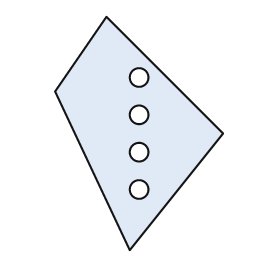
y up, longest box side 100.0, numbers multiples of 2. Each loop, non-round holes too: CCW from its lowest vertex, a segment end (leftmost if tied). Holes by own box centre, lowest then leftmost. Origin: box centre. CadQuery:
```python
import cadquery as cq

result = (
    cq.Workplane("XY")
    .moveTo(-4.0, -50.0)
    .lineTo(36.0, 0.0)
    .lineTo(-14.0, 50.0)
    .lineTo(-36.0, 18.0)
    .close()
    .moveTo(0.0, -24.0)
    .circle(4.0)
    .moveTo(0.0, -8.0)
    .circle(4.0)
    .moveTo(0.0, 8.0)
    .circle(4.0)
    .moveTo(0.0, 24.0)
    .circle(4.0)
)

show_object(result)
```